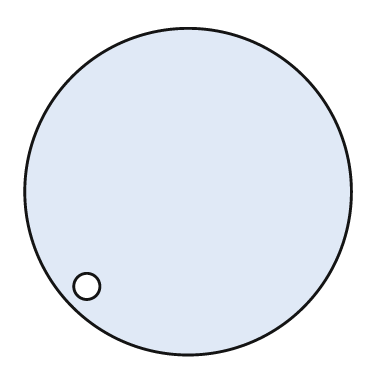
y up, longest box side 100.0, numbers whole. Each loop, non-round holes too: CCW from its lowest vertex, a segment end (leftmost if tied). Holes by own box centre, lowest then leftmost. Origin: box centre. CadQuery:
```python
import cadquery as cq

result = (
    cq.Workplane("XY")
    .moveTo(0.0, 0.0)
    .circle(50.0)
    .moveTo(-31.0, -29.0)
    .circle(4.0)
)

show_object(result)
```